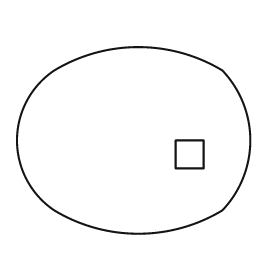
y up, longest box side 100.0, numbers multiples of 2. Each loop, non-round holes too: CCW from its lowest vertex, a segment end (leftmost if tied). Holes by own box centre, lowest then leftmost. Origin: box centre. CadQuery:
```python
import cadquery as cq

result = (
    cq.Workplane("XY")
    .moveTo(-34.0, -30.0)
    .threePointArc((2.0, -40.0), (38.0, -30.0))
    .threePointArc((50.0, 0.0), (38.0, 30.0))
    .threePointArc((2.0, 40.0), (-34.0, 30.0))
    .threePointArc((-50.0, 0.0), (-34.0, -30.0))
    .close()
    .moveTo(18.0, -12.0)
    .lineTo(30.0, -12.0)
    .lineTo(30.0, 0.0)
    .lineTo(18.0, 0.0)
    .close()
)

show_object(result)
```